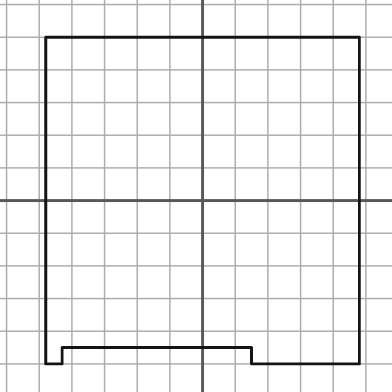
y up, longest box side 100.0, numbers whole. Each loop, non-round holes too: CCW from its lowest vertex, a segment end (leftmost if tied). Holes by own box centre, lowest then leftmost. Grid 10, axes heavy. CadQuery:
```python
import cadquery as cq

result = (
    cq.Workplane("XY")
    .moveTo(-48.0, -50.0)
    .lineTo(-43.0, -50.0)
    .lineTo(-43.0, -45.0)
    .lineTo(15.0, -45.0)
    .lineTo(15.0, -50.0)
    .lineTo(48.0, -50.0)
    .lineTo(48.0, 50.0)
    .lineTo(-48.0, 50.0)
    .close()
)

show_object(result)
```